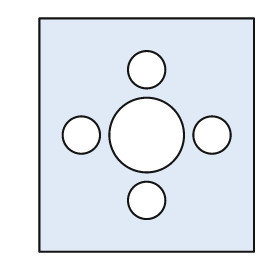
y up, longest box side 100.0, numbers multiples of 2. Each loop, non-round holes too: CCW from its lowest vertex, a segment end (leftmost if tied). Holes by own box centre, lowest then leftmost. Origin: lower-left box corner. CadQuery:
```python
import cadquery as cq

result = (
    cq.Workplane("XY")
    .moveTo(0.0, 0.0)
    .lineTo(92.0, 0.0)
    .lineTo(92.0, 100.0)
    .lineTo(0.0, 100.0)
    .close()
    .moveTo(46.0, 22.0)
    .circle(8.0)
    .moveTo(18.0, 50.0)
    .circle(8.0)
    .moveTo(46.0, 50.0)
    .circle(16.0)
    .moveTo(74.0, 50.0)
    .circle(8.0)
    .moveTo(46.0, 78.0)
    .circle(8.0)
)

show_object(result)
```